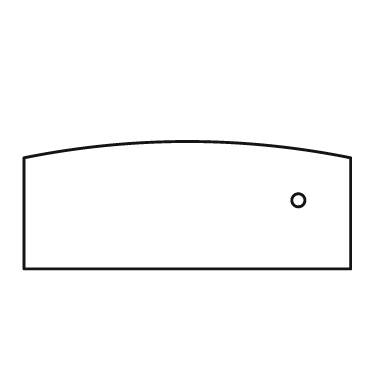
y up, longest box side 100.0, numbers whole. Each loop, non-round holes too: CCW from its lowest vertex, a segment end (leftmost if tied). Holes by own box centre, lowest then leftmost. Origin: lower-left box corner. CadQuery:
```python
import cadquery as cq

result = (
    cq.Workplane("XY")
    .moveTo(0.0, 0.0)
    .lineTo(100.0, 0.0)
    .lineTo(100.0, 34.0)
    .threePointArc((50.0, 39.0), (0.0, 34.0))
    .close()
    .moveTo(84.0, 21.0)
    .circle(2.0)
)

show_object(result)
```